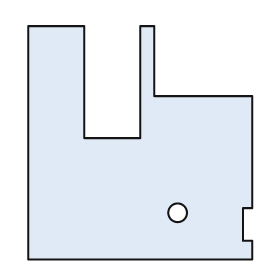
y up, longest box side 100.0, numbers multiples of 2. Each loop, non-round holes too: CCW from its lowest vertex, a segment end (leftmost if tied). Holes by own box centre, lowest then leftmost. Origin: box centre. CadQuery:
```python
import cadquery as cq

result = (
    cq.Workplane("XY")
    .moveTo(-48.0, -50.0)
    .lineTo(48.0, -50.0)
    .lineTo(48.0, -42.0)
    .lineTo(44.0, -42.0)
    .lineTo(44.0, -28.0)
    .lineTo(48.0, -28.0)
    .lineTo(48.0, 20.0)
    .lineTo(6.0, 20.0)
    .lineTo(6.0, 50.0)
    .lineTo(0.0, 50.0)
    .lineTo(0.0, 2.0)
    .lineTo(-24.0, 2.0)
    .lineTo(-24.0, 50.0)
    .lineTo(-48.0, 50.0)
    .close()
    .moveTo(16.0, -30.0)
    .circle(4.0)
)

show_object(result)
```